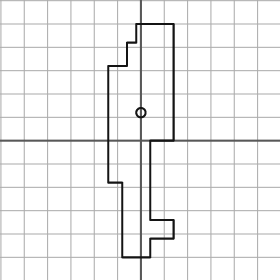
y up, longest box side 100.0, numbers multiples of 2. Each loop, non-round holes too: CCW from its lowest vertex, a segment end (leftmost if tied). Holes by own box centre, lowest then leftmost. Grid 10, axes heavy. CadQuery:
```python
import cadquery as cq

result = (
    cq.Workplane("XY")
    .moveTo(-8.0, -50.0)
    .lineTo(4.0, -50.0)
    .lineTo(4.0, -42.0)
    .lineTo(14.0, -42.0)
    .lineTo(14.0, -34.0)
    .lineTo(4.0, -34.0)
    .lineTo(4.0, 0.0)
    .lineTo(14.0, 0.0)
    .lineTo(14.0, 50.0)
    .lineTo(-2.0, 50.0)
    .lineTo(-2.0, 42.0)
    .lineTo(-6.0, 42.0)
    .lineTo(-6.0, 32.0)
    .lineTo(-14.0, 32.0)
    .lineTo(-14.0, -18.0)
    .lineTo(-8.0, -18.0)
    .close()
    .moveTo(0.0, 12.0)
    .circle(2.0)
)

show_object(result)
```